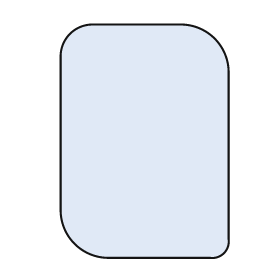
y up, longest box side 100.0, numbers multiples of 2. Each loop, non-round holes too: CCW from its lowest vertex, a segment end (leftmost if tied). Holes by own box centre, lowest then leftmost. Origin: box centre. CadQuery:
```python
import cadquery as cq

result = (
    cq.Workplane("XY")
    .moveTo(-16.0, -50.0)
    .lineTo(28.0, -50.0)
    .threePointArc((34.0, -48.0), (36.0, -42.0))
    .lineTo(36.0, 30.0)
    .threePointArc((30.0, 44.0), (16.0, 50.0))
    .lineTo(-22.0, 50.0)
    .threePointArc((-32.0, 46.0), (-36.0, 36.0))
    .lineTo(-36.0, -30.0)
    .threePointArc((-30.0, -44.0), (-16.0, -50.0))
    .close()
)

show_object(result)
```